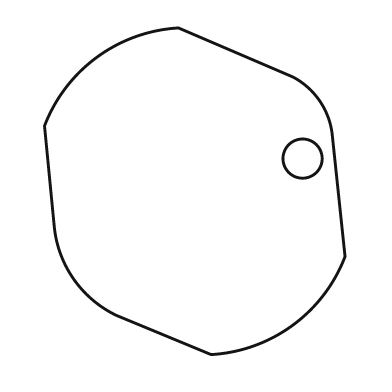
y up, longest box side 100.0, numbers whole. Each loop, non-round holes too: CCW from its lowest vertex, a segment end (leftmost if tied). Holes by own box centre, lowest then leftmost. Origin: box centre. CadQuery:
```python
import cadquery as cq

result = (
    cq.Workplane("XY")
    .moveTo(5.0, -50.0)
    .threePointArc((30.0, -41.0), (46.0, -20.0))
    .lineTo(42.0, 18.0)
    .threePointArc((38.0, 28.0), (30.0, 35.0))
    .lineTo(-5.0, 50.0)
    .threePointArc((-30.0, 41.0), (-46.0, 20.0))
    .lineTo(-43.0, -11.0)
    .threePointArc((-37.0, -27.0), (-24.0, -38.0))
    .close()
    .moveTo(33.0, 10.0)
    .circle(6.0)
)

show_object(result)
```